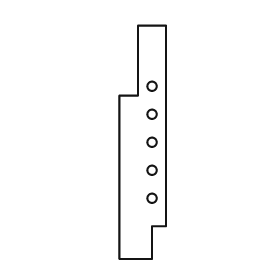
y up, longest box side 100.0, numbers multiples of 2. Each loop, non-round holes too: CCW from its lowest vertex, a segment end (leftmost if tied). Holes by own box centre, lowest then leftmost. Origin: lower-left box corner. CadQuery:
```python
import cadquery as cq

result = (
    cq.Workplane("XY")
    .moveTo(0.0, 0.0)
    .lineTo(14.0, 0.0)
    .lineTo(14.0, 14.0)
    .lineTo(20.0, 14.0)
    .lineTo(20.0, 100.0)
    .lineTo(8.0, 100.0)
    .lineTo(8.0, 70.0)
    .lineTo(0.0, 70.0)
    .close()
    .moveTo(14.0, 26.0)
    .circle(2.0)
    .moveTo(14.0, 38.0)
    .circle(2.0)
    .moveTo(14.0, 50.0)
    .circle(2.0)
    .moveTo(14.0, 62.0)
    .circle(2.0)
    .moveTo(14.0, 74.0)
    .circle(2.0)
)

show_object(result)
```